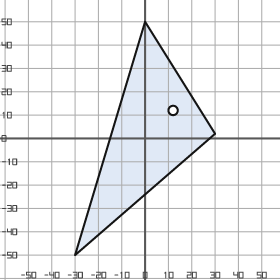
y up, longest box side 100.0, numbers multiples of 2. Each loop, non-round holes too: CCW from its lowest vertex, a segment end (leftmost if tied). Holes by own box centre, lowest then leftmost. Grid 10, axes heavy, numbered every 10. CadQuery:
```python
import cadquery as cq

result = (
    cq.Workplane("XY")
    .moveTo(-30.0, -50.0)
    .lineTo(30.0, 2.0)
    .lineTo(0.0, 50.0)
    .close()
    .moveTo(12.0, 12.0)
    .circle(2.0)
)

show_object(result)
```